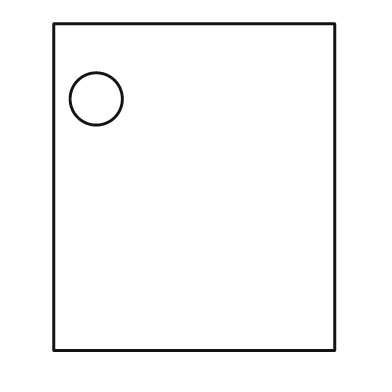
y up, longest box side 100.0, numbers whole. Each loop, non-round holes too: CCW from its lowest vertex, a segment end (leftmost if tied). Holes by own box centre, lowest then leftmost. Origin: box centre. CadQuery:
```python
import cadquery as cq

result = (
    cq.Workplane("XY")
    .moveTo(-43.0, -50.0)
    .lineTo(43.0, -50.0)
    .lineTo(43.0, 50.0)
    .lineTo(-43.0, 50.0)
    .close()
    .moveTo(-30.0, 27.0)
    .circle(8.0)
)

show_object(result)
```